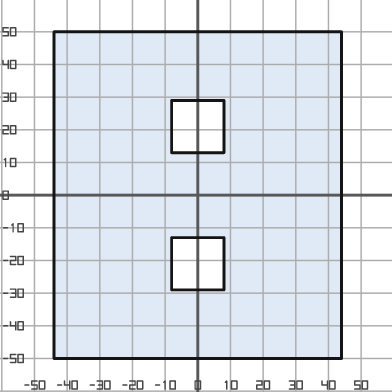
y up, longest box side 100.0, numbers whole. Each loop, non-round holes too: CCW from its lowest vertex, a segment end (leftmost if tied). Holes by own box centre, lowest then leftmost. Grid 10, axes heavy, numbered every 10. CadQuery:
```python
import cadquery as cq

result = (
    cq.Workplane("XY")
    .moveTo(-44.0, -50.0)
    .lineTo(44.0, -50.0)
    .lineTo(44.0, 50.0)
    .lineTo(-44.0, 50.0)
    .close()
    .moveTo(-8.0, -29.0)
    .lineTo(8.0, -29.0)
    .lineTo(8.0, -13.0)
    .lineTo(-8.0, -13.0)
    .close()
    .moveTo(-8.0, 13.0)
    .lineTo(8.0, 13.0)
    .lineTo(8.0, 29.0)
    .lineTo(-8.0, 29.0)
    .close()
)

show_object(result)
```